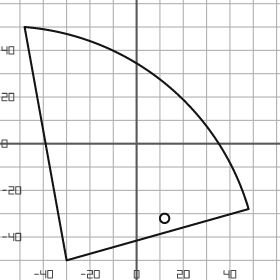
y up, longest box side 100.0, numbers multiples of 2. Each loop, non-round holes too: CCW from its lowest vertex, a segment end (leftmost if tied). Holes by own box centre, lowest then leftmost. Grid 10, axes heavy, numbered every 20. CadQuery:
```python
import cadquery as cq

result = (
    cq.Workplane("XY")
    .moveTo(-30.0, -50.0)
    .lineTo(48.0, -28.0)
    .threePointArc((12.0, 26.0), (-48.0, 50.0))
    .close()
    .moveTo(12.0, -32.0)
    .circle(2.0)
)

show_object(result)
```